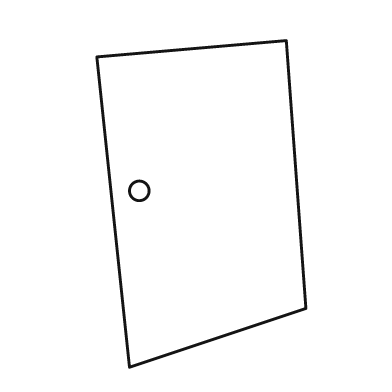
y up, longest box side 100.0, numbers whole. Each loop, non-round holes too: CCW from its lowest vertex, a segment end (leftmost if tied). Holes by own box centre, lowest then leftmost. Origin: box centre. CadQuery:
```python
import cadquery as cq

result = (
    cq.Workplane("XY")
    .moveTo(-22.0, -50.0)
    .lineTo(32.0, -32.0)
    .lineTo(26.0, 50.0)
    .lineTo(-32.0, 45.0)
    .close()
    .moveTo(-19.0, 4.0)
    .circle(3.0)
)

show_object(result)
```